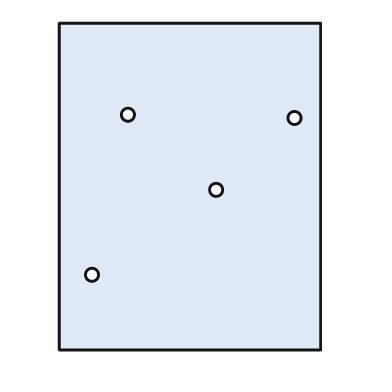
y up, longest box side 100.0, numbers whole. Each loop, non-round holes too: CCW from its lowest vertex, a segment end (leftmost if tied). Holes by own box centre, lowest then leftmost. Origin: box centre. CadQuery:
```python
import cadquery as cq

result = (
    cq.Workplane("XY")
    .moveTo(-40.0, -50.0)
    .lineTo(40.0, -50.0)
    .lineTo(40.0, 50.0)
    .lineTo(-40.0, 50.0)
    .close()
    .moveTo(-30.0, -27.0)
    .circle(2.0)
    .moveTo(8.0, -1.0)
    .circle(2.0)
    .moveTo(32.0, 21.0)
    .circle(2.0)
    .moveTo(-19.0, 22.0)
    .circle(2.0)
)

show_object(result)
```